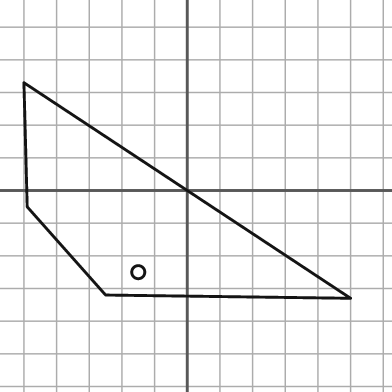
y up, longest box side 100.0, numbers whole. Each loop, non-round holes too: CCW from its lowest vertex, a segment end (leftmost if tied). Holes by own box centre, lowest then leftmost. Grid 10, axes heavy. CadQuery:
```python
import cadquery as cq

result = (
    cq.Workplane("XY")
    .moveTo(50.0, -33.0)
    .lineTo(-50.0, 33.0)
    .lineTo(-49.0, -5.0)
    .lineTo(-25.0, -32.0)
    .close()
    .moveTo(-15.0, -25.0)
    .circle(2.0)
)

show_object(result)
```